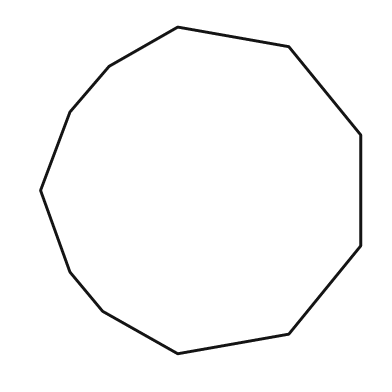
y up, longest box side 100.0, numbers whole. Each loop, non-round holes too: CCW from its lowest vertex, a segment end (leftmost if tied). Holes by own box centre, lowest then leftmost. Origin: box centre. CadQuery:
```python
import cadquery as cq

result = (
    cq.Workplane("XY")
    .moveTo(-7.0, -50.0)
    .lineTo(27.0, -44.0)
    .lineTo(49.0, -17.0)
    .lineTo(49.0, 17.0)
    .lineTo(27.0, 44.0)
    .lineTo(-7.0, 50.0)
    .lineTo(-28.0, 38.0)
    .lineTo(-40.0, 24.0)
    .lineTo(-49.0, 0.0)
    .lineTo(-40.0, -25.0)
    .lineTo(-30.0, -37.0)
    .close()
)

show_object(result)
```